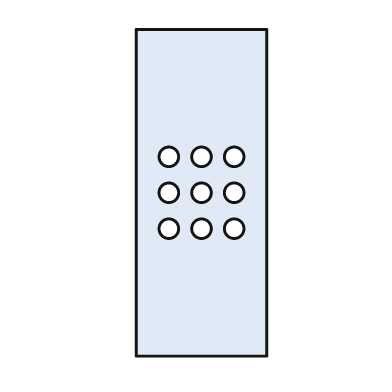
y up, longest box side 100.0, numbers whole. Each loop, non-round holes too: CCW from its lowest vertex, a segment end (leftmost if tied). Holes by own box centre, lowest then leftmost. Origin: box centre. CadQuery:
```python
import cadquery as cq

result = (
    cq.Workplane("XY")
    .moveTo(-20.0, -50.0)
    .lineTo(20.0, -50.0)
    .lineTo(20.0, 50.0)
    .lineTo(-20.0, 50.0)
    .close()
    .moveTo(-10.0, -11.0)
    .circle(3.0)
    .moveTo(0.0, -11.0)
    .circle(3.0)
    .moveTo(10.0, -11.0)
    .circle(3.0)
    .moveTo(-10.0, 0.0)
    .circle(3.0)
    .moveTo(0.0, 0.0)
    .circle(3.0)
    .moveTo(10.0, 0.0)
    .circle(3.0)
    .moveTo(-10.0, 11.0)
    .circle(3.0)
    .moveTo(0.0, 11.0)
    .circle(3.0)
    .moveTo(10.0, 11.0)
    .circle(3.0)
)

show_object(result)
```